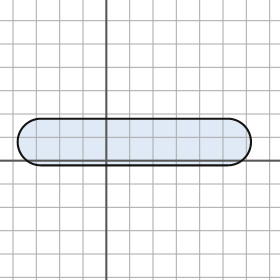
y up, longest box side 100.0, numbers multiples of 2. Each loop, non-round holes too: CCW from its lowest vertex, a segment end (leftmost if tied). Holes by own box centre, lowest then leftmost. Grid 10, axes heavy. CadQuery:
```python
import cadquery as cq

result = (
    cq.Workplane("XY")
    .moveTo(-28.0, -2.0)
    .lineTo(52.0, -2.0)
    .threePointArc((62.0, 8.0), (52.0, 18.0))
    .lineTo(-28.0, 18.0)
    .threePointArc((-38.0, 8.0), (-28.0, -2.0))
    .close()
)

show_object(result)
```